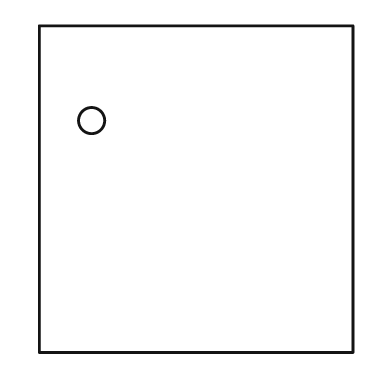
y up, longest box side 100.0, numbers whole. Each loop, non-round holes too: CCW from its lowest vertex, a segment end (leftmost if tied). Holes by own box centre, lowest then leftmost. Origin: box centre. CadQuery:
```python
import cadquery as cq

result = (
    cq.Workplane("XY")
    .moveTo(-48.0, -50.0)
    .lineTo(48.0, -50.0)
    .lineTo(48.0, 50.0)
    .lineTo(-48.0, 50.0)
    .close()
    .moveTo(-32.0, 21.0)
    .circle(4.0)
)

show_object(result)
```